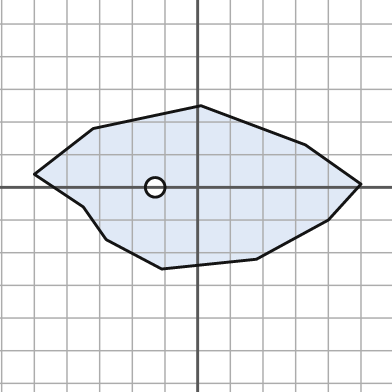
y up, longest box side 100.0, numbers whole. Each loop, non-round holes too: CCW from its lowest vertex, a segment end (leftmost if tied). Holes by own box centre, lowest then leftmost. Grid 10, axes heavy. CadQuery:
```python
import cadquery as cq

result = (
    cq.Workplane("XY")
    .moveTo(-11.0, -25.0)
    .lineTo(18.0, -22.0)
    .lineTo(40.0, -10.0)
    .lineTo(50.0, 1.0)
    .lineTo(33.0, 13.0)
    .lineTo(1.0, 25.0)
    .lineTo(-32.0, 18.0)
    .lineTo(-50.0, 4.0)
    .lineTo(-35.0, -6.0)
    .lineTo(-28.0, -16.0)
    .close()
    .moveTo(-13.0, 0.0)
    .circle(3.0)
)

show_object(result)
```